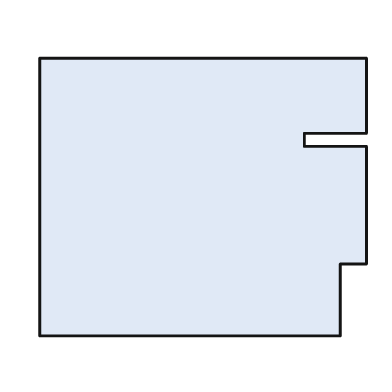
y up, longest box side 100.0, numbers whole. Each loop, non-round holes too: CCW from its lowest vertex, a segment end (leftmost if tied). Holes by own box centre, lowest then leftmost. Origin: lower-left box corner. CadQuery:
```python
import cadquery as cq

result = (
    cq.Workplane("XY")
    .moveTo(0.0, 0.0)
    .lineTo(92.0, 0.0)
    .lineTo(92.0, 22.0)
    .lineTo(100.0, 22.0)
    .lineTo(100.0, 58.0)
    .lineTo(81.0, 58.0)
    .lineTo(81.0, 62.0)
    .lineTo(100.0, 62.0)
    .lineTo(100.0, 85.0)
    .lineTo(0.0, 85.0)
    .close()
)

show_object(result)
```